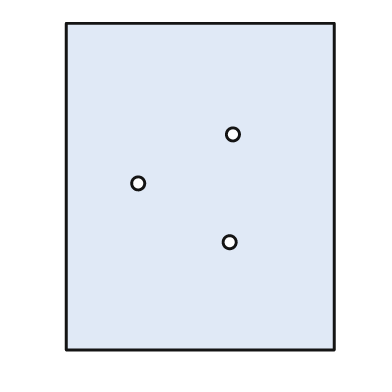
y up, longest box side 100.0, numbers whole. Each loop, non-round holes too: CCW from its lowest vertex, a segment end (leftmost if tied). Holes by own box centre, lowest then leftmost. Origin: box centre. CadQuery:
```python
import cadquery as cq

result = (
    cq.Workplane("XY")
    .moveTo(-41.0, -50.0)
    .lineTo(41.0, -50.0)
    .lineTo(41.0, 50.0)
    .lineTo(-41.0, 50.0)
    .close()
    .moveTo(9.0, -17.0)
    .circle(2.0)
    .moveTo(-19.0, 1.0)
    .circle(2.0)
    .moveTo(10.0, 16.0)
    .circle(2.0)
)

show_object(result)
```